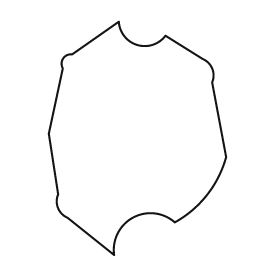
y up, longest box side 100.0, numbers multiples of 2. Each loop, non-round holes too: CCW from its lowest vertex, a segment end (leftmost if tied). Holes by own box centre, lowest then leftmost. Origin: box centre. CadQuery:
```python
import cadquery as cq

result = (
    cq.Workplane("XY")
    .moveTo(-10.0, -50.0)
    .threePointArc((-2.0, -34.0), (16.0, -36.0))
    .threePointArc((30.0, -24.0), (38.0, -8.0))
    .lineTo(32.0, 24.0)
    .threePointArc((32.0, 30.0), (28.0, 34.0))
    .lineTo(12.0, 44.0)
    .threePointArc((0.0, 40.0), (-8.0, 50.0))
    .lineTo(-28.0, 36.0)
    .threePointArc((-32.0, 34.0), (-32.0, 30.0))
    .lineTo(-38.0, 2.0)
    .lineTo(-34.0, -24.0)
    .threePointArc((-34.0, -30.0), (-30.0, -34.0))
    .close()
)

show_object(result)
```